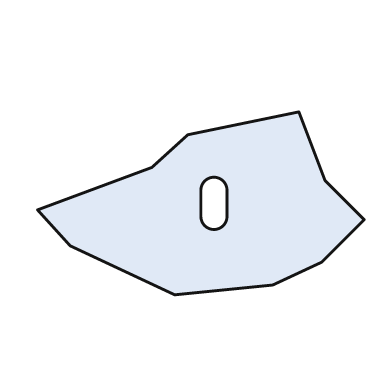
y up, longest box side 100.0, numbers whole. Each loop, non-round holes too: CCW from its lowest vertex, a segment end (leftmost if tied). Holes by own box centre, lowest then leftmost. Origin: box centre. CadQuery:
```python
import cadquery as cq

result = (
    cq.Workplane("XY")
    .moveTo(-8.0, -28.0)
    .lineTo(22.0, -25.0)
    .lineTo(37.0, -18.0)
    .lineTo(50.0, -5.0)
    .lineTo(38.0, 7.0)
    .lineTo(30.0, 28.0)
    .lineTo(-4.0, 21.0)
    .lineTo(-15.0, 11.0)
    .lineTo(-50.0, -2.0)
    .lineTo(-40.0, -13.0)
    .close()
    .moveTo(0.0, -4.0)
    .threePointArc((4.0, -8.0), (8.0, -4.0))
    .lineTo(8.0, 4.0)
    .threePointArc((4.0, 8.0), (0.0, 4.0))
    .close()
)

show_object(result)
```